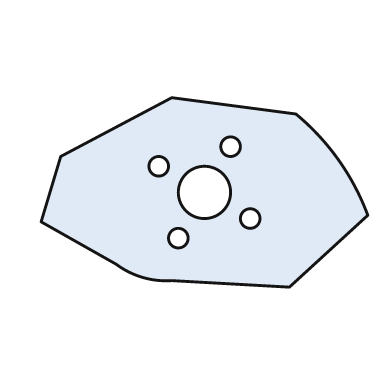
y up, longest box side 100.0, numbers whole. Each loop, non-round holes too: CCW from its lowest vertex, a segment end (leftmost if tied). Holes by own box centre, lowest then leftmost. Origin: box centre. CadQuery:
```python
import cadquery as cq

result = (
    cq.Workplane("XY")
    .moveTo(26.0, -29.0)
    .lineTo(50.0, -7.0)
    .threePointArc((41.0, 10.0), (28.0, 24.0))
    .lineTo(-10.0, 29.0)
    .lineTo(-44.0, 11.0)
    .lineTo(-50.0, -9.0)
    .lineTo(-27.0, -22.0)
    .threePointArc((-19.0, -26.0), (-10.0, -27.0))
    .close()
    .moveTo(-8.0, -14.0)
    .circle(3.0)
    .moveTo(14.0, -8.0)
    .circle(3.0)
    .moveTo(0.0, 0.0)
    .circle(8.0)
    .moveTo(-14.0, 8.0)
    .circle(3.0)
    .moveTo(8.0, 14.0)
    .circle(3.0)
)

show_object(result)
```